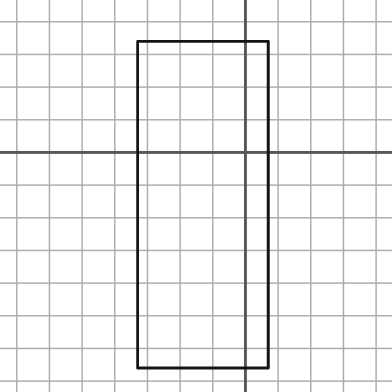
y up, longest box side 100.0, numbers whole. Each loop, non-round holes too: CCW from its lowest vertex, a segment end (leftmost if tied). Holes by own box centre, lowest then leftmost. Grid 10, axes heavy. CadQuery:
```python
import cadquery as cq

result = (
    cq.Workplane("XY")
    .moveTo(-33.0, -66.0)
    .lineTo(7.0, -66.0)
    .lineTo(7.0, 34.0)
    .lineTo(-33.0, 34.0)
    .close()
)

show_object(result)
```